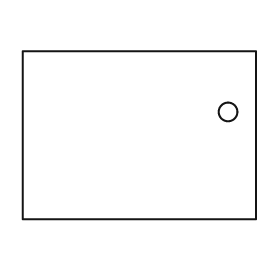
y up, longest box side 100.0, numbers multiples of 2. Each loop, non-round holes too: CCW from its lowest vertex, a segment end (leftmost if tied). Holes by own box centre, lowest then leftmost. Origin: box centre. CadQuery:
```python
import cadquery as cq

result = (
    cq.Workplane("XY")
    .moveTo(-50.0, -36.0)
    .lineTo(50.0, -36.0)
    .lineTo(50.0, 36.0)
    .lineTo(-50.0, 36.0)
    .close()
    .moveTo(38.0, 10.0)
    .circle(4.0)
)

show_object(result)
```